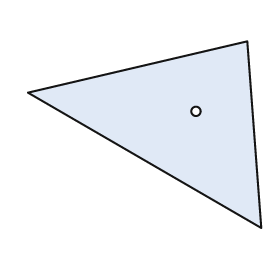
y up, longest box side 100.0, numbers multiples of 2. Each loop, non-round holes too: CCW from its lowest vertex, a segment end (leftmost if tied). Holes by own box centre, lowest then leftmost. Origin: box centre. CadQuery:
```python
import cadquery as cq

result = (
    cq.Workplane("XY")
    .moveTo(50.0, -40.0)
    .lineTo(44.0, 40.0)
    .lineTo(-50.0, 18.0)
    .close()
    .moveTo(22.0, 10.0)
    .circle(2.0)
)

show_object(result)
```